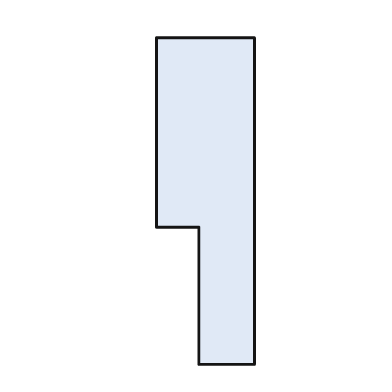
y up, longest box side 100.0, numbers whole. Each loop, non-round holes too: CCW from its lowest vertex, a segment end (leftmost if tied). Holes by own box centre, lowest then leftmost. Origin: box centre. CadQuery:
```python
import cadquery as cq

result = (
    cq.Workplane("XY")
    .moveTo(-2.0, -50.0)
    .lineTo(15.0, -50.0)
    .lineTo(15.0, 50.0)
    .lineTo(-15.0, 50.0)
    .lineTo(-15.0, -8.0)
    .lineTo(-2.0, -8.0)
    .close()
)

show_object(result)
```